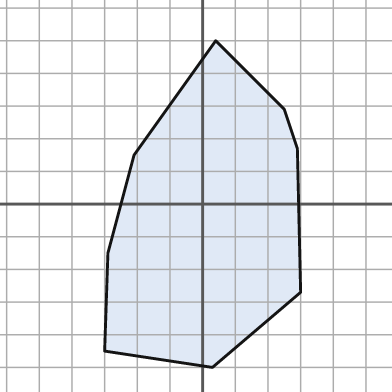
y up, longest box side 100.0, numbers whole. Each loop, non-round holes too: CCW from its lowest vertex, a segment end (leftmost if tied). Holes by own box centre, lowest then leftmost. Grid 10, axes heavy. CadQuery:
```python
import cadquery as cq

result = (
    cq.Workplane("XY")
    .moveTo(3.0, -50.0)
    .lineTo(30.0, -27.0)
    .lineTo(29.0, 17.0)
    .lineTo(25.0, 29.0)
    .lineTo(4.0, 50.0)
    .lineTo(-21.0, 15.0)
    .lineTo(-29.0, -15.0)
    .lineTo(-30.0, -45.0)
    .close()
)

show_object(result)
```